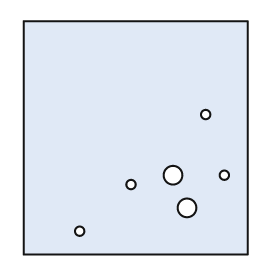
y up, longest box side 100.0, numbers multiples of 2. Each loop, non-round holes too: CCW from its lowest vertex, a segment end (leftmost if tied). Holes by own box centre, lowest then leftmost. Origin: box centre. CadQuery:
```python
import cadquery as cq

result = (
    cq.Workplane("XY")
    .moveTo(-48.0, -50.0)
    .lineTo(48.0, -50.0)
    .lineTo(48.0, 50.0)
    .lineTo(-48.0, 50.0)
    .close()
    .moveTo(-24.0, -40.0)
    .circle(2.0)
    .moveTo(22.0, -30.0)
    .circle(4.0)
    .moveTo(-2.0, -20.0)
    .circle(2.0)
    .moveTo(16.0, -16.0)
    .circle(4.0)
    .moveTo(38.0, -16.0)
    .circle(2.0)
    .moveTo(30.0, 10.0)
    .circle(2.0)
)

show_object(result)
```